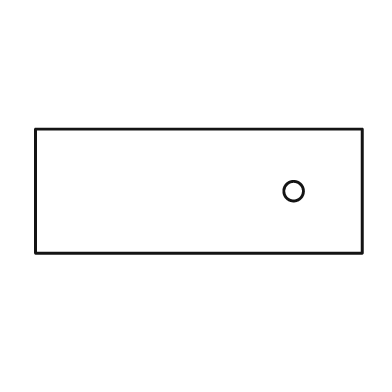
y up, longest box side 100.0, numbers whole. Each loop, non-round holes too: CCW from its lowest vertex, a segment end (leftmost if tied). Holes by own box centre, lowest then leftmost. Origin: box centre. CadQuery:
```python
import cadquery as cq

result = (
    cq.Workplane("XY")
    .moveTo(-50.0, -19.0)
    .lineTo(50.0, -19.0)
    .lineTo(50.0, 19.0)
    .lineTo(-50.0, 19.0)
    .close()
    .moveTo(29.0, 0.0)
    .circle(3.0)
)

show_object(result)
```